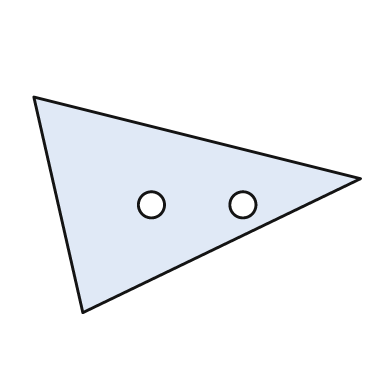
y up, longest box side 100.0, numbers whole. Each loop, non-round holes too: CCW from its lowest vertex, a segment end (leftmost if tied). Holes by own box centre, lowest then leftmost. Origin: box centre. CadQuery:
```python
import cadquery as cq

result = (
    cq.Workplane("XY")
    .moveTo(-35.0, -33.0)
    .lineTo(50.0, 8.0)
    .lineTo(-50.0, 33.0)
    .close()
    .moveTo(-14.0, 0.0)
    .circle(4.0)
    .moveTo(14.0, 0.0)
    .circle(4.0)
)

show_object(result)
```